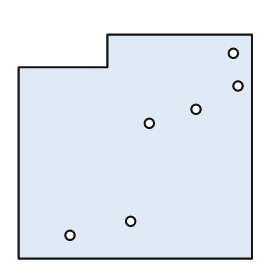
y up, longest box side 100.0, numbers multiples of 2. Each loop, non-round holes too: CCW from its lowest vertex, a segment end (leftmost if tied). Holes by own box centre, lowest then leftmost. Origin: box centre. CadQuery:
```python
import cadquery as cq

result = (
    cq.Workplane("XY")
    .moveTo(-50.0, -48.0)
    .lineTo(50.0, -48.0)
    .lineTo(50.0, 48.0)
    .lineTo(-12.0, 48.0)
    .lineTo(-12.0, 34.0)
    .lineTo(-50.0, 34.0)
    .close()
    .moveTo(-28.0, -38.0)
    .circle(2.0)
    .moveTo(-2.0, -32.0)
    .circle(2.0)
    .moveTo(6.0, 10.0)
    .circle(2.0)
    .moveTo(26.0, 16.0)
    .circle(2.0)
    .moveTo(44.0, 26.0)
    .circle(2.0)
    .moveTo(42.0, 40.0)
    .circle(2.0)
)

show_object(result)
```